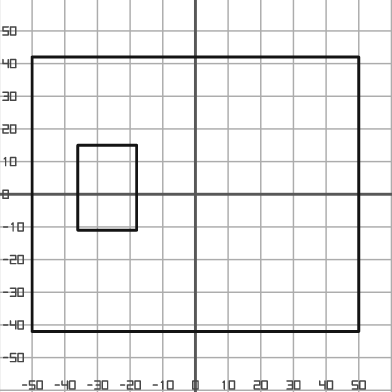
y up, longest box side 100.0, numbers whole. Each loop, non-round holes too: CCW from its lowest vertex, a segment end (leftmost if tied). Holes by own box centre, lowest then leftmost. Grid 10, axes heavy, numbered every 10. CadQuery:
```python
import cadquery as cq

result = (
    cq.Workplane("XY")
    .moveTo(-50.0, -42.0)
    .lineTo(50.0, -42.0)
    .lineTo(50.0, 42.0)
    .lineTo(-50.0, 42.0)
    .close()
    .moveTo(-36.0, -11.0)
    .lineTo(-18.0, -11.0)
    .lineTo(-18.0, 15.0)
    .lineTo(-36.0, 15.0)
    .close()
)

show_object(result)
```